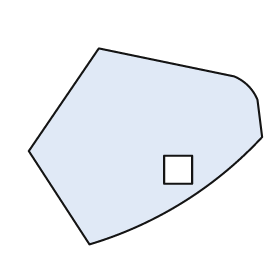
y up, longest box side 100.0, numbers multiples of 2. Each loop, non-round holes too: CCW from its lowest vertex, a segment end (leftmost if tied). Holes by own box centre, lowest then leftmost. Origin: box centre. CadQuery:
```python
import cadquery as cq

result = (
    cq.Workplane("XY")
    .moveTo(-24.0, -42.0)
    .threePointArc((16.0, -24.0), (50.0, 4.0))
    .lineTo(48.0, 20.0)
    .threePointArc((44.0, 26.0), (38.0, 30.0))
    .lineTo(-20.0, 42.0)
    .lineTo(-50.0, -2.0)
    .close()
    .moveTo(8.0, -16.0)
    .lineTo(20.0, -16.0)
    .lineTo(20.0, -4.0)
    .lineTo(8.0, -4.0)
    .close()
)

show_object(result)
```